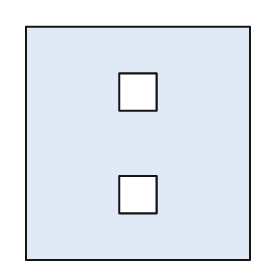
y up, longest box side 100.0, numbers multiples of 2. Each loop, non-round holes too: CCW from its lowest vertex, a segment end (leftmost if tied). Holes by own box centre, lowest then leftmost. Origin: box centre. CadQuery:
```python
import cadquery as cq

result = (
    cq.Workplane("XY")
    .moveTo(-48.0, -50.0)
    .lineTo(48.0, -50.0)
    .lineTo(48.0, 50.0)
    .lineTo(-48.0, 50.0)
    .close()
    .moveTo(-8.0, -30.0)
    .lineTo(8.0, -30.0)
    .lineTo(8.0, -14.0)
    .lineTo(-8.0, -14.0)
    .close()
    .moveTo(-8.0, 14.0)
    .lineTo(8.0, 14.0)
    .lineTo(8.0, 30.0)
    .lineTo(-8.0, 30.0)
    .close()
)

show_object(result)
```